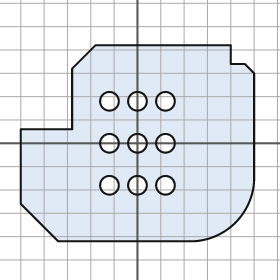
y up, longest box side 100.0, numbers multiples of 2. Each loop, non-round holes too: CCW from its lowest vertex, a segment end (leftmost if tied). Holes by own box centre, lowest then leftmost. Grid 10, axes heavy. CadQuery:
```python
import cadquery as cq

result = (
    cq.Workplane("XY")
    .moveTo(-34.0, -42.0)
    .lineTo(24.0, -42.0)
    .threePointArc((42.0, -34.0), (50.0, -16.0))
    .lineTo(50.0, 30.0)
    .lineTo(46.0, 34.0)
    .lineTo(40.0, 34.0)
    .lineTo(40.0, 42.0)
    .lineTo(-18.0, 42.0)
    .lineTo(-28.0, 32.0)
    .lineTo(-28.0, 6.0)
    .lineTo(-50.0, 6.0)
    .lineTo(-50.0, -26.0)
    .close()
    .moveTo(-12.0, -18.0)
    .circle(4.0)
    .moveTo(0.0, -18.0)
    .circle(4.0)
    .moveTo(12.0, -18.0)
    .circle(4.0)
    .moveTo(-12.0, 0.0)
    .circle(4.0)
    .moveTo(0.0, 0.0)
    .circle(4.0)
    .moveTo(12.0, 0.0)
    .circle(4.0)
    .moveTo(-12.0, 18.0)
    .circle(4.0)
    .moveTo(0.0, 18.0)
    .circle(4.0)
    .moveTo(12.0, 18.0)
    .circle(4.0)
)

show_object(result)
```